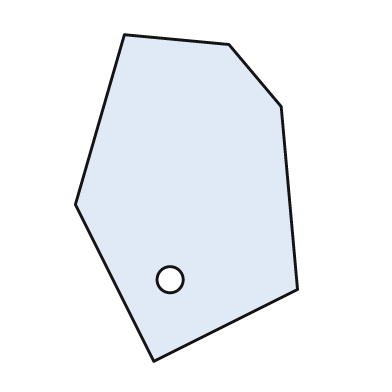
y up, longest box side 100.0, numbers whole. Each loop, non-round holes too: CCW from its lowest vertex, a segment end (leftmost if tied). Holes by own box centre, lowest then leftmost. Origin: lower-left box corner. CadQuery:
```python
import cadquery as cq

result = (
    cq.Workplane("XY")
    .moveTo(24.0, 0.0)
    .lineTo(68.0, 22.0)
    .lineTo(63.0, 78.0)
    .lineTo(47.0, 97.0)
    .lineTo(15.0, 100.0)
    .lineTo(0.0, 48.0)
    .close()
    .moveTo(29.0, 25.0)
    .circle(4.0)
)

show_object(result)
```